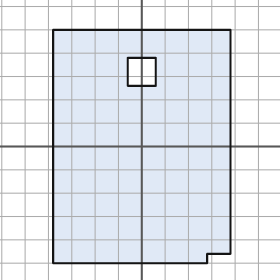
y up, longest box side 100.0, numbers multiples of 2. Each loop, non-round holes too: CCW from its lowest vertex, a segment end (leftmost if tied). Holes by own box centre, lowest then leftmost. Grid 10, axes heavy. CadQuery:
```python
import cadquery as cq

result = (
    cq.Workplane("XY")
    .moveTo(-38.0, -50.0)
    .lineTo(28.0, -50.0)
    .lineTo(28.0, -46.0)
    .lineTo(38.0, -46.0)
    .lineTo(38.0, 50.0)
    .lineTo(-38.0, 50.0)
    .close()
    .moveTo(-6.0, 26.0)
    .lineTo(6.0, 26.0)
    .lineTo(6.0, 38.0)
    .lineTo(-6.0, 38.0)
    .close()
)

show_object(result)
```